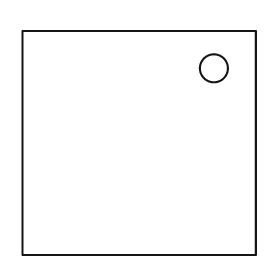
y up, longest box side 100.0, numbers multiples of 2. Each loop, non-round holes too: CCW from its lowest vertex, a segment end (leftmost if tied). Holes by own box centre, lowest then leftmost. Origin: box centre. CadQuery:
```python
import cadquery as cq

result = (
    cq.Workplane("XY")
    .moveTo(-50.0, -48.0)
    .lineTo(50.0, -48.0)
    .lineTo(50.0, 48.0)
    .lineTo(-50.0, 48.0)
    .close()
    .moveTo(32.0, 32.0)
    .circle(6.0)
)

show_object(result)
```